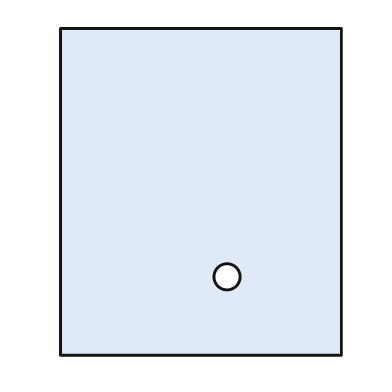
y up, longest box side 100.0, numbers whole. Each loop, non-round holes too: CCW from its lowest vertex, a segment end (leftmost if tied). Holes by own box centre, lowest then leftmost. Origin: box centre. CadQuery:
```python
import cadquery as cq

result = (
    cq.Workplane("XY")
    .moveTo(-43.0, -50.0)
    .lineTo(43.0, -50.0)
    .lineTo(43.0, 50.0)
    .lineTo(-43.0, 50.0)
    .close()
    .moveTo(8.0, -26.0)
    .circle(4.0)
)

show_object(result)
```